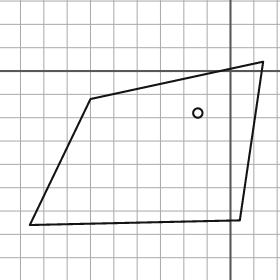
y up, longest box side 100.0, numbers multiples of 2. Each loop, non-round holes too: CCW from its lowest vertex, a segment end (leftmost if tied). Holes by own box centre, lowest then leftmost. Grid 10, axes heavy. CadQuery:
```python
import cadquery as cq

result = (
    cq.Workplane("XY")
    .moveTo(-86.0, -66.0)
    .lineTo(4.0, -64.0)
    .lineTo(14.0, 4.0)
    .lineTo(-60.0, -12.0)
    .close()
    .moveTo(-14.0, -18.0)
    .circle(2.0)
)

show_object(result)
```